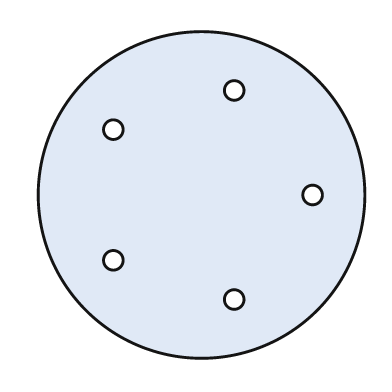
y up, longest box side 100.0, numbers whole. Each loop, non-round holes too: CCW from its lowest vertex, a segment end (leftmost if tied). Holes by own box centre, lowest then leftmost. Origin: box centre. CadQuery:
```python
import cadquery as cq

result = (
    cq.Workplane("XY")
    .moveTo(0.0, 0.0)
    .circle(50.0)
    .moveTo(10.0, -32.0)
    .circle(3.0)
    .moveTo(-27.0, -20.0)
    .circle(3.0)
    .moveTo(34.0, 0.0)
    .circle(3.0)
    .moveTo(-27.0, 20.0)
    .circle(3.0)
    .moveTo(10.0, 32.0)
    .circle(3.0)
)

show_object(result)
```